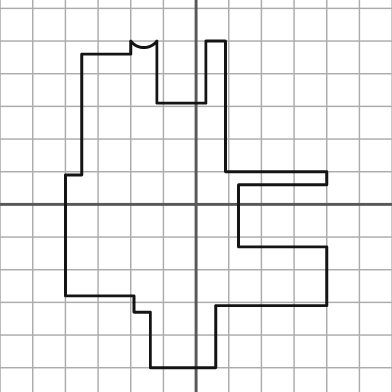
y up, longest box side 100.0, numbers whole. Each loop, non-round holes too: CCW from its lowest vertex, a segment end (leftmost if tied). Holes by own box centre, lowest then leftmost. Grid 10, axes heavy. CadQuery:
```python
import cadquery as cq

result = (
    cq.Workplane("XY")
    .moveTo(-14.0, -50.0)
    .lineTo(6.0, -50.0)
    .lineTo(6.0, -31.0)
    .lineTo(40.0, -31.0)
    .lineTo(40.0, -13.0)
    .lineTo(13.0, -13.0)
    .lineTo(13.0, 6.0)
    .lineTo(40.0, 6.0)
    .lineTo(40.0, 10.0)
    .lineTo(9.0, 10.0)
    .lineTo(9.0, 50.0)
    .lineTo(3.0, 50.0)
    .lineTo(3.0, 31.0)
    .lineTo(-12.0, 31.0)
    .lineTo(-12.0, 50.0)
    .threePointArc((-16.0, 48.0), (-20.0, 50.0))
    .lineTo(-20.0, 46.0)
    .lineTo(-35.0, 46.0)
    .lineTo(-35.0, 9.0)
    .lineTo(-40.0, 9.0)
    .lineTo(-40.0, -28.0)
    .lineTo(-19.0, -28.0)
    .lineTo(-19.0, -33.0)
    .lineTo(-14.0, -33.0)
    .close()
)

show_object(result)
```